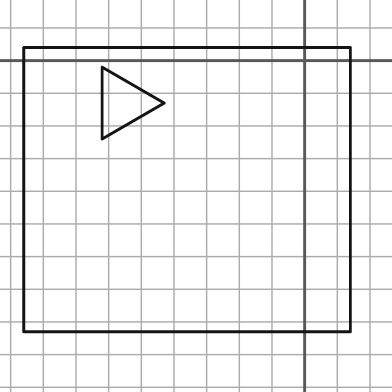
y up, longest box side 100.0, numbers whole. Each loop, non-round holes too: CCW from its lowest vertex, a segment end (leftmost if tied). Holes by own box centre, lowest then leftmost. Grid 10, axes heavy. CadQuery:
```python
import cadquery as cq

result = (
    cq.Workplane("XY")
    .moveTo(-86.0, -83.0)
    .lineTo(14.0, -83.0)
    .lineTo(14.0, 4.0)
    .lineTo(-86.0, 4.0)
    .close()
    .moveTo(-62.0, -24.0)
    .lineTo(-43.0, -13.0)
    .lineTo(-62.0, -2.0)
    .close()
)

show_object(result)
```